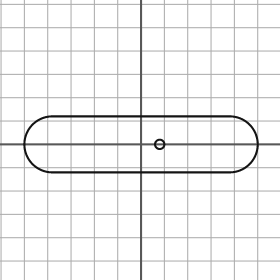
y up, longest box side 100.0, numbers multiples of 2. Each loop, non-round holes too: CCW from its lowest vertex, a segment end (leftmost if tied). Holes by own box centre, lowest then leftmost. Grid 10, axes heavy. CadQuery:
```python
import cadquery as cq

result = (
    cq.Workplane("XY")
    .moveTo(-38.0, -12.0)
    .lineTo(38.0, -12.0)
    .threePointArc((50.0, 0.0), (38.0, 12.0))
    .lineTo(-38.0, 12.0)
    .threePointArc((-50.0, 0.0), (-38.0, -12.0))
    .close()
    .moveTo(8.0, 0.0)
    .circle(2.0)
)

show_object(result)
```